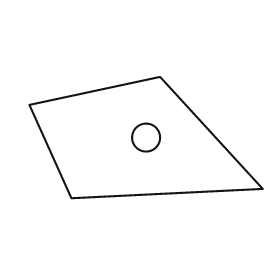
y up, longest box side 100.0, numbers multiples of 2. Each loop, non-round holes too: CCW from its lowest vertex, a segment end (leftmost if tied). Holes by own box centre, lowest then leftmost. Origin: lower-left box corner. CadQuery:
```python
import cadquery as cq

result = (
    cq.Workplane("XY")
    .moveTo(18.0, 0.0)
    .lineTo(100.0, 4.0)
    .lineTo(56.0, 52.0)
    .lineTo(0.0, 40.0)
    .close()
    .moveTo(50.0, 26.0)
    .circle(6.0)
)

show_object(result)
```